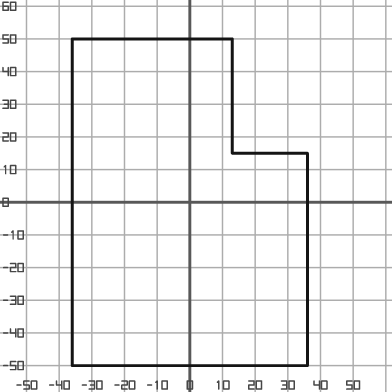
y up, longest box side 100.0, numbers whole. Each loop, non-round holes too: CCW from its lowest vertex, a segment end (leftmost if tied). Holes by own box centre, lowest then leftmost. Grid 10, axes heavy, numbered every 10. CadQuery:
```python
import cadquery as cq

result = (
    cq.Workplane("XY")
    .moveTo(-36.0, -50.0)
    .lineTo(36.0, -50.0)
    .lineTo(36.0, 15.0)
    .lineTo(13.0, 15.0)
    .lineTo(13.0, 50.0)
    .lineTo(-36.0, 50.0)
    .close()
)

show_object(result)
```